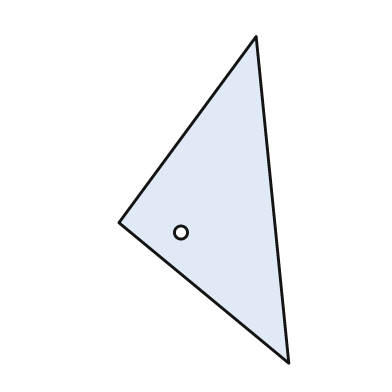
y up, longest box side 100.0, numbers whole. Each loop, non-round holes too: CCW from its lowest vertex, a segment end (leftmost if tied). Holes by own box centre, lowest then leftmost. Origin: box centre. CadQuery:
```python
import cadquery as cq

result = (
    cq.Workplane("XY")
    .moveTo(26.0, -50.0)
    .lineTo(16.0, 50.0)
    .lineTo(-26.0, -7.0)
    .close()
    .moveTo(-7.0, -10.0)
    .circle(2.0)
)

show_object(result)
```